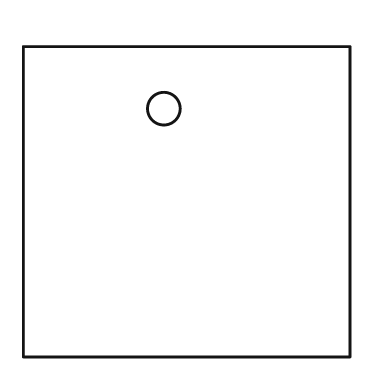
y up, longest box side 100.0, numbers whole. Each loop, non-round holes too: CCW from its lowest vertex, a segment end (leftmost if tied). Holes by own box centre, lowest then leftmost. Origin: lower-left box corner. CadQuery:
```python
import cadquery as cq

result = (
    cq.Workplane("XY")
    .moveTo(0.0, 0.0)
    .lineTo(100.0, 0.0)
    .lineTo(100.0, 95.0)
    .lineTo(0.0, 95.0)
    .close()
    .moveTo(43.0, 76.0)
    .circle(5.0)
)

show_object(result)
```